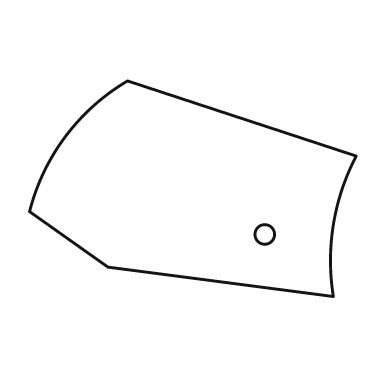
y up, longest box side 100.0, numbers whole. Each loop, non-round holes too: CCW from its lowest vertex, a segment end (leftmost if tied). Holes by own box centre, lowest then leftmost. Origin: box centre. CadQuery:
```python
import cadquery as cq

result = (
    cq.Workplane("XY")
    .moveTo(43.0, -33.0)
    .threePointArc((43.0, -11.0), (50.0, 10.0))
    .lineTo(-20.0, 33.0)
    .threePointArc((-39.0, 16.0), (-50.0, -7.0))
    .lineTo(-26.0, -24.0)
    .close()
    .moveTo(22.0, -14.0)
    .circle(3.0)
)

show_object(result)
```